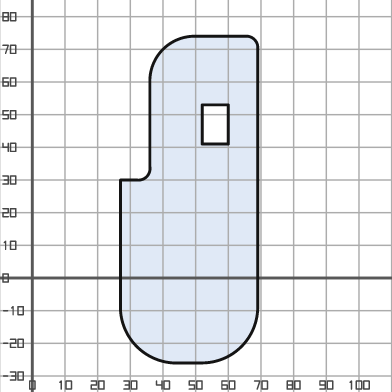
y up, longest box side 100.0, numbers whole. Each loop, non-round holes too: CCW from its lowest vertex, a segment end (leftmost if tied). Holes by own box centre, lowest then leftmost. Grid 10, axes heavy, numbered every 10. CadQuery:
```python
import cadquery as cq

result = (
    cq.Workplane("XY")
    .moveTo(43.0, -26.0)
    .lineTo(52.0, -26.0)
    .threePointArc((64.0, -21.0), (69.0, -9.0))
    .lineTo(69.0, 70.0)
    .threePointArc((68.0, 73.0), (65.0, 74.0))
    .lineTo(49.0, 74.0)
    .threePointArc((40.0, 70.0), (36.0, 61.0))
    .lineTo(36.0, 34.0)
    .threePointArc((35.0, 31.0), (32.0, 30.0))
    .lineTo(27.0, 30.0)
    .lineTo(27.0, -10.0)
    .threePointArc((32.0, -21.0), (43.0, -26.0))
    .close()
    .moveTo(52.0, 41.0)
    .lineTo(60.0, 41.0)
    .lineTo(60.0, 53.0)
    .lineTo(52.0, 53.0)
    .close()
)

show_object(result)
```